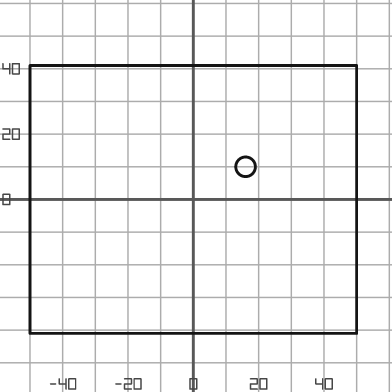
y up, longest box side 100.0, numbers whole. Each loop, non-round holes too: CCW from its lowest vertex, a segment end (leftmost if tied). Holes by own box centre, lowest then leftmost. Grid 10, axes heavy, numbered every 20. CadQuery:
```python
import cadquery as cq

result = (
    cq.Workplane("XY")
    .moveTo(-50.0, -41.0)
    .lineTo(50.0, -41.0)
    .lineTo(50.0, 41.0)
    .lineTo(-50.0, 41.0)
    .close()
    .moveTo(16.0, 10.0)
    .circle(3.0)
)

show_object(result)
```